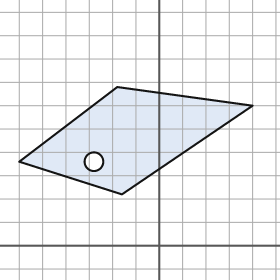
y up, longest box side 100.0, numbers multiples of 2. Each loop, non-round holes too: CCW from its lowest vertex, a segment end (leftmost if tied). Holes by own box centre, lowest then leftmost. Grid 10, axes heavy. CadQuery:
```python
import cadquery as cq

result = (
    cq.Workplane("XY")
    .moveTo(-16.0, 22.0)
    .lineTo(40.0, 60.0)
    .lineTo(-18.0, 68.0)
    .lineTo(-60.0, 36.0)
    .close()
    .moveTo(-28.0, 36.0)
    .circle(4.0)
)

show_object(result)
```